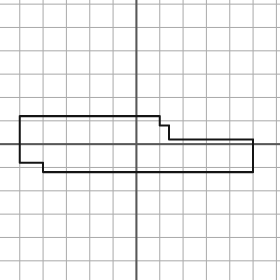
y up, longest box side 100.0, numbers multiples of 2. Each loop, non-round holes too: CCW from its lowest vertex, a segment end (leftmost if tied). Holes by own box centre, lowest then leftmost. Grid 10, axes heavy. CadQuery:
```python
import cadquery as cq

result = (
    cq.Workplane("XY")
    .moveTo(-40.0, -12.0)
    .lineTo(50.0, -12.0)
    .lineTo(50.0, 2.0)
    .lineTo(14.0, 2.0)
    .lineTo(14.0, 8.0)
    .lineTo(10.0, 8.0)
    .lineTo(10.0, 12.0)
    .lineTo(-50.0, 12.0)
    .lineTo(-50.0, -8.0)
    .lineTo(-40.0, -8.0)
    .close()
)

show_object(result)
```